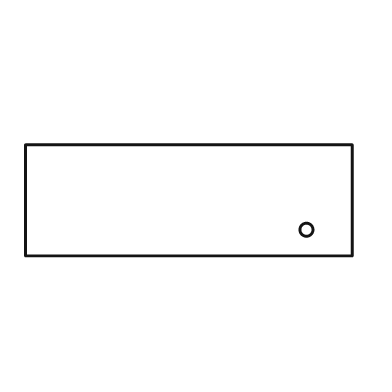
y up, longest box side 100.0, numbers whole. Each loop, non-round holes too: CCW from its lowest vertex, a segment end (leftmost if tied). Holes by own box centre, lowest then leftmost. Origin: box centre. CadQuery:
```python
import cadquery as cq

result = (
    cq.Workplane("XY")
    .moveTo(-50.0, -17.0)
    .lineTo(50.0, -17.0)
    .lineTo(50.0, 17.0)
    .lineTo(-50.0, 17.0)
    .close()
    .moveTo(36.0, -9.0)
    .circle(2.0)
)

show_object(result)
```